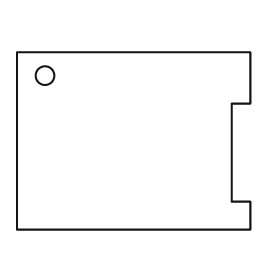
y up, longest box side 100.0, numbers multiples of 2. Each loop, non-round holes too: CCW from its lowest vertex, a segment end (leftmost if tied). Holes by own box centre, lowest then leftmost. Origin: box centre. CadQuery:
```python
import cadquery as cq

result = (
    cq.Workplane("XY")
    .moveTo(-50.0, -38.0)
    .lineTo(50.0, -38.0)
    .lineTo(50.0, -26.0)
    .lineTo(42.0, -26.0)
    .lineTo(42.0, 16.0)
    .lineTo(50.0, 16.0)
    .lineTo(50.0, 38.0)
    .lineTo(-50.0, 38.0)
    .close()
    .moveTo(-38.0, 28.0)
    .circle(4.0)
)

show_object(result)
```